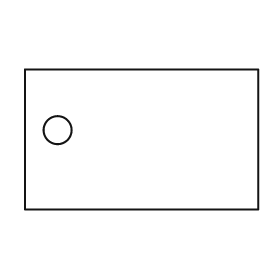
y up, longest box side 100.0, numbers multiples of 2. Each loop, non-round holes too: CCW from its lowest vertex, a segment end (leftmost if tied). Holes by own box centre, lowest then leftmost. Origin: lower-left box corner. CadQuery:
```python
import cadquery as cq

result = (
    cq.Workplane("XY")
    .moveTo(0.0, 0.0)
    .lineTo(100.0, 0.0)
    .lineTo(100.0, 60.0)
    .lineTo(0.0, 60.0)
    .close()
    .moveTo(14.0, 34.0)
    .circle(6.0)
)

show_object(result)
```